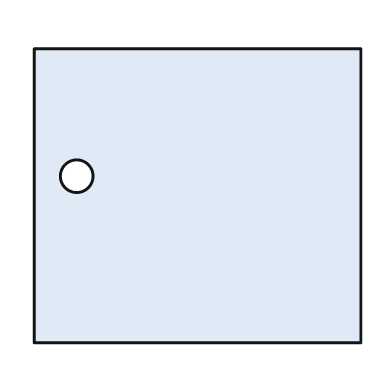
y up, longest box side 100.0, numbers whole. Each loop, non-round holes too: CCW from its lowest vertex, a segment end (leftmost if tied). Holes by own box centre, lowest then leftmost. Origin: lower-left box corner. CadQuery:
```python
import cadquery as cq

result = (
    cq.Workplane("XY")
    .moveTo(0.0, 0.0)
    .lineTo(100.0, 0.0)
    .lineTo(100.0, 90.0)
    .lineTo(0.0, 90.0)
    .close()
    .moveTo(13.0, 51.0)
    .circle(5.0)
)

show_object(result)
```